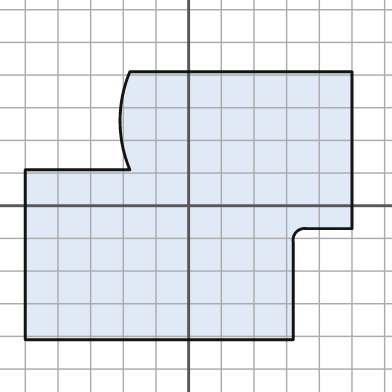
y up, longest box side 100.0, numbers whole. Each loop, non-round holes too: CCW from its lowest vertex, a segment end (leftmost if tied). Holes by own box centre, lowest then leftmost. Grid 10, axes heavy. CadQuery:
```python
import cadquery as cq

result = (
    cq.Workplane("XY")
    .moveTo(-50.0, -41.0)
    .lineTo(32.0, -41.0)
    .lineTo(32.0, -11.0)
    .threePointArc((33.0, -8.0), (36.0, -7.0))
    .lineTo(50.0, -7.0)
    .lineTo(50.0, 41.0)
    .lineTo(-18.0, 41.0)
    .threePointArc((-21.0, 26.0), (-18.0, 11.0))
    .lineTo(-50.0, 11.0)
    .close()
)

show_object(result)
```